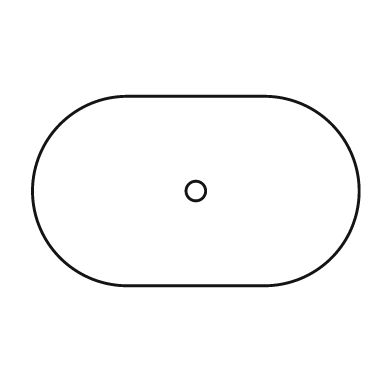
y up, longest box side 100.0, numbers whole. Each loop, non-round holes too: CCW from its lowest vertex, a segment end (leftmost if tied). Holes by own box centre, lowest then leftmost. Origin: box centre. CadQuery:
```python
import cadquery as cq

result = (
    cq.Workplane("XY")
    .moveTo(-21.0, -29.0)
    .lineTo(21.0, -29.0)
    .threePointArc((50.0, 0.0), (21.0, 29.0))
    .lineTo(-21.0, 29.0)
    .threePointArc((-50.0, 0.0), (-21.0, -29.0))
    .close()
    .moveTo(0.0, 0.0)
    .circle(3.0)
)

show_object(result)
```